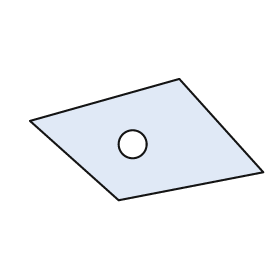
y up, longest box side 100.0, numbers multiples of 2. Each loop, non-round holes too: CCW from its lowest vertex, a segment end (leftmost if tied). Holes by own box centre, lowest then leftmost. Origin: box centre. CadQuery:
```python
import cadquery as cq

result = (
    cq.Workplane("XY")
    .moveTo(-12.0, -26.0)
    .lineTo(50.0, -14.0)
    .lineTo(14.0, 26.0)
    .lineTo(-50.0, 8.0)
    .close()
    .moveTo(-6.0, -2.0)
    .circle(6.0)
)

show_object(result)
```